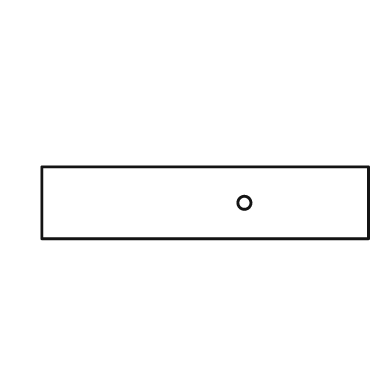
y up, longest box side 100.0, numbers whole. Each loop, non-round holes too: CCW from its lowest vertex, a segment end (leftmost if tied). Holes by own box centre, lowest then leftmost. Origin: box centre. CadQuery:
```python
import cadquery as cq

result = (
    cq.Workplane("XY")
    .moveTo(-50.0, -11.0)
    .lineTo(50.0, -11.0)
    .lineTo(50.0, 11.0)
    .lineTo(-50.0, 11.0)
    .close()
    .moveTo(12.0, 0.0)
    .circle(2.0)
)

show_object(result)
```